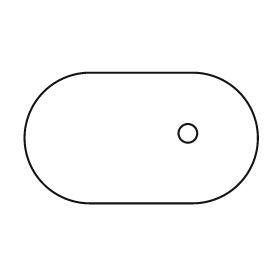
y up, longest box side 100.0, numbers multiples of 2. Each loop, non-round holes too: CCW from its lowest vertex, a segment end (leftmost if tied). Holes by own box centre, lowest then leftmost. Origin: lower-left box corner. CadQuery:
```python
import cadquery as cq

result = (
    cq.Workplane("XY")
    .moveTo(28.0, 0.0)
    .lineTo(72.0, 0.0)
    .threePointArc((100.0, 28.0), (72.0, 56.0))
    .lineTo(28.0, 56.0)
    .threePointArc((0.0, 28.0), (28.0, 0.0))
    .close()
    .moveTo(70.0, 30.0)
    .circle(4.0)
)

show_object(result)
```